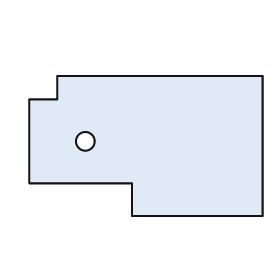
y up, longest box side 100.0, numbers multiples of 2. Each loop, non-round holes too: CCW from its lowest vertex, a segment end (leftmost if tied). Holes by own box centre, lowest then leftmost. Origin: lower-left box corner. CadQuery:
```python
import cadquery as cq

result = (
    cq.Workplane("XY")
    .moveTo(44.0, 0.0)
    .lineTo(100.0, 0.0)
    .lineTo(100.0, 60.0)
    .lineTo(12.0, 60.0)
    .lineTo(12.0, 50.0)
    .lineTo(0.0, 50.0)
    .lineTo(0.0, 14.0)
    .lineTo(44.0, 14.0)
    .close()
    .moveTo(24.0, 32.0)
    .circle(4.0)
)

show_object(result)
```